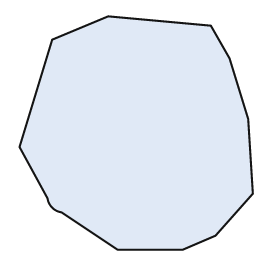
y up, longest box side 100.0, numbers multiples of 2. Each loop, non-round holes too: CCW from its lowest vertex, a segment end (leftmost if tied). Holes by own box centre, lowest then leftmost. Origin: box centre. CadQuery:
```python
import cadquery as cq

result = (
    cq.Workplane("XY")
    .moveTo(-8.0, -50.0)
    .lineTo(20.0, -50.0)
    .lineTo(34.0, -44.0)
    .lineTo(50.0, -26.0)
    .lineTo(48.0, 6.0)
    .lineTo(40.0, 32.0)
    .lineTo(32.0, 46.0)
    .lineTo(-12.0, 50.0)
    .lineTo(-36.0, 40.0)
    .lineTo(-50.0, -6.0)
    .lineTo(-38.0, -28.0)
    .threePointArc((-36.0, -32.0), (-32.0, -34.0))
    .close()
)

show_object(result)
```